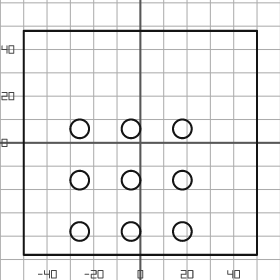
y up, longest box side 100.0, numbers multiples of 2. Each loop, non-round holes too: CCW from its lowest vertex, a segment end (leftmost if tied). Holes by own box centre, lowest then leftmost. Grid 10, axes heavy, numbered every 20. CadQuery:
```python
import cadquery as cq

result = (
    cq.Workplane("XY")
    .moveTo(-50.0, -48.0)
    .lineTo(50.0, -48.0)
    .lineTo(50.0, 48.0)
    .lineTo(-50.0, 48.0)
    .close()
    .moveTo(-26.0, -38.0)
    .circle(4.0)
    .moveTo(-4.0, -38.0)
    .circle(4.0)
    .moveTo(18.0, -38.0)
    .circle(4.0)
    .moveTo(-26.0, -16.0)
    .circle(4.0)
    .moveTo(-4.0, -16.0)
    .circle(4.0)
    .moveTo(18.0, -16.0)
    .circle(4.0)
    .moveTo(-26.0, 6.0)
    .circle(4.0)
    .moveTo(-4.0, 6.0)
    .circle(4.0)
    .moveTo(18.0, 6.0)
    .circle(4.0)
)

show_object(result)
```